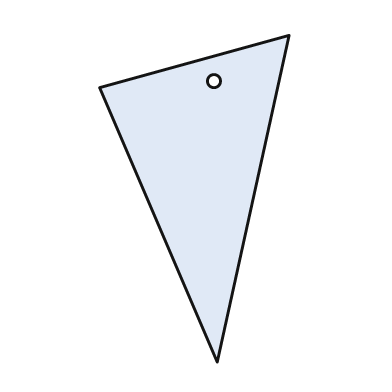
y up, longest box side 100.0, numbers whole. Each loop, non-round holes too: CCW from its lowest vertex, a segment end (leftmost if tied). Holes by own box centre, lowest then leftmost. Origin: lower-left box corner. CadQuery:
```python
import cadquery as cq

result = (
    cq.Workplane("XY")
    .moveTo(36.0, 0.0)
    .lineTo(58.0, 100.0)
    .lineTo(0.0, 84.0)
    .close()
    .moveTo(35.0, 86.0)
    .circle(2.0)
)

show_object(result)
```